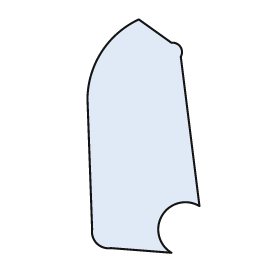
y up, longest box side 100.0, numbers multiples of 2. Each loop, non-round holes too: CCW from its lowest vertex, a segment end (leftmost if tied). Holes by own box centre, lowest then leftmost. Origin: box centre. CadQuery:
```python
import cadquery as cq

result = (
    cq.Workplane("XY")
    .moveTo(12.0, -50.0)
    .threePointArc((8.0, -34.0), (24.0, -30.0))
    .lineTo(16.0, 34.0)
    .threePointArc((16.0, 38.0), (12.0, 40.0))
    .lineTo(-2.0, 50.0)
    .threePointArc((-18.0, 36.0), (-24.0, 16.0))
    .lineTo(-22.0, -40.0)
    .threePointArc((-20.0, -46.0), (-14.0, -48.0))
    .close()
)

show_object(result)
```